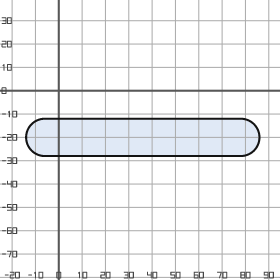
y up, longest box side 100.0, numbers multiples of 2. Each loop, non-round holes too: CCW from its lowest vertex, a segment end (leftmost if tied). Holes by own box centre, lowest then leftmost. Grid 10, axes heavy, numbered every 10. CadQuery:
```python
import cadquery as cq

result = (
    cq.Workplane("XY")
    .moveTo(-6.0, -28.0)
    .lineTo(78.0, -28.0)
    .threePointArc((86.0, -20.0), (78.0, -12.0))
    .lineTo(-6.0, -12.0)
    .threePointArc((-14.0, -20.0), (-6.0, -28.0))
    .close()
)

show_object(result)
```